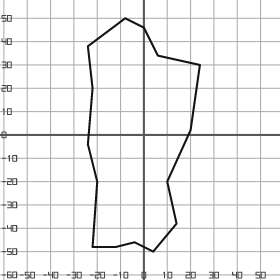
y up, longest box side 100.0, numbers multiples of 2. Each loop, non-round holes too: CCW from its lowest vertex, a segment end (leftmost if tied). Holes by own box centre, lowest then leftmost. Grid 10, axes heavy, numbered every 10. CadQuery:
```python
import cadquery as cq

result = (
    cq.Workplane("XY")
    .moveTo(4.0, -50.0)
    .lineTo(14.0, -38.0)
    .lineTo(10.0, -20.0)
    .lineTo(20.0, 2.0)
    .lineTo(24.0, 30.0)
    .lineTo(6.0, 34.0)
    .lineTo(0.0, 46.0)
    .lineTo(-8.0, 50.0)
    .lineTo(-24.0, 38.0)
    .lineTo(-22.0, 20.0)
    .lineTo(-24.0, -4.0)
    .lineTo(-20.0, -20.0)
    .lineTo(-22.0, -48.0)
    .lineTo(-12.0, -48.0)
    .lineTo(-4.0, -46.0)
    .close()
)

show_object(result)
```